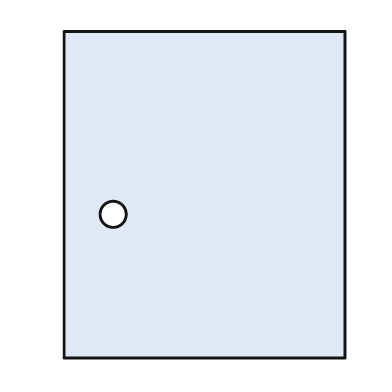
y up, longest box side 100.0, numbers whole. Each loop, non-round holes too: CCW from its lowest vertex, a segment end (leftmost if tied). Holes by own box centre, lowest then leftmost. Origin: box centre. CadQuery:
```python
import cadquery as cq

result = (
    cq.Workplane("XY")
    .moveTo(-43.0, -50.0)
    .lineTo(43.0, -50.0)
    .lineTo(43.0, 50.0)
    .lineTo(-43.0, 50.0)
    .close()
    .moveTo(-28.0, -6.0)
    .circle(4.0)
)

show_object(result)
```